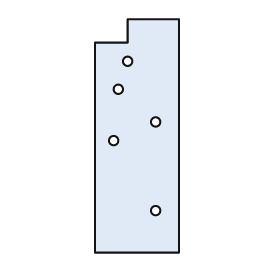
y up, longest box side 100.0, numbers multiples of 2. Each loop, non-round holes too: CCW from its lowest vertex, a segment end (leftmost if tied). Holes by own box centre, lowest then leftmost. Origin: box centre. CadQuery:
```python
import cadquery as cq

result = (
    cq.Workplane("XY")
    .moveTo(-18.0, -50.0)
    .lineTo(18.0, -50.0)
    .lineTo(18.0, 50.0)
    .lineTo(-4.0, 50.0)
    .lineTo(-4.0, 40.0)
    .lineTo(-18.0, 40.0)
    .close()
    .moveTo(8.0, -32.0)
    .circle(2.0)
    .moveTo(-10.0, -2.0)
    .circle(2.0)
    .moveTo(8.0, 6.0)
    .circle(2.0)
    .moveTo(-8.0, 20.0)
    .circle(2.0)
    .moveTo(-4.0, 32.0)
    .circle(2.0)
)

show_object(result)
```